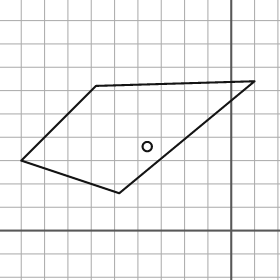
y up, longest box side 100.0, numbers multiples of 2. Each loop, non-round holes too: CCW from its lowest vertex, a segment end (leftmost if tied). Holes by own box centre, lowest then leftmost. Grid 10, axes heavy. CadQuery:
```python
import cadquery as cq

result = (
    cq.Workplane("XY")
    .moveTo(-48.0, 16.0)
    .lineTo(10.0, 64.0)
    .lineTo(-58.0, 62.0)
    .lineTo(-90.0, 30.0)
    .close()
    .moveTo(-36.0, 36.0)
    .circle(2.0)
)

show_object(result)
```